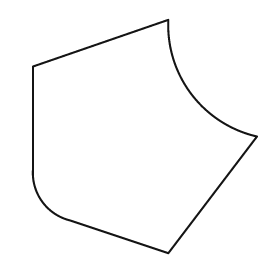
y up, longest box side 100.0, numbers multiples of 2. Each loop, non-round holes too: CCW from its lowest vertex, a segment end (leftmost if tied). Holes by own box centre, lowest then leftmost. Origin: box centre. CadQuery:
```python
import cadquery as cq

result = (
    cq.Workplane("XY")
    .moveTo(10.0, -50.0)
    .lineTo(48.0, 0.0)
    .threePointArc((20.0, 18.0), (10.0, 50.0))
    .lineTo(-48.0, 30.0)
    .lineTo(-48.0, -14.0)
    .threePointArc((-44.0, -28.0), (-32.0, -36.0))
    .close()
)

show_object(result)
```